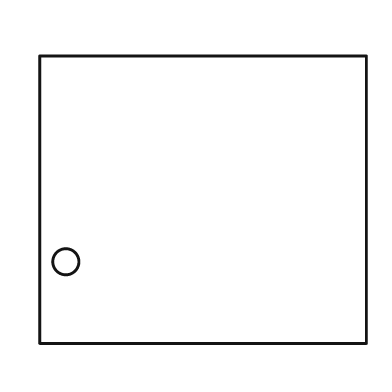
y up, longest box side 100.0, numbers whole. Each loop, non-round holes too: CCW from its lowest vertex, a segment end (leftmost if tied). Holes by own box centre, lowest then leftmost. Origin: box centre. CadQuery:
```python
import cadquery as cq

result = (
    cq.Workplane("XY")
    .moveTo(-50.0, -44.0)
    .lineTo(50.0, -44.0)
    .lineTo(50.0, 44.0)
    .lineTo(-50.0, 44.0)
    .close()
    .moveTo(-42.0, -19.0)
    .circle(4.0)
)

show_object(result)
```